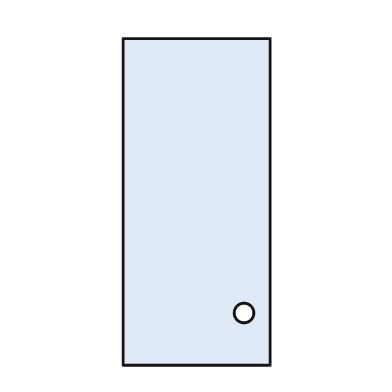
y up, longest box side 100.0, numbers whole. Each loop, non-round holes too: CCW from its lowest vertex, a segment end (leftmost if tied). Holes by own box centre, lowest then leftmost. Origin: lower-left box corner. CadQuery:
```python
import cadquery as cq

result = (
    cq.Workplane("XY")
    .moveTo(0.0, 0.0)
    .lineTo(45.0, 0.0)
    .lineTo(45.0, 100.0)
    .lineTo(0.0, 100.0)
    .close()
    .moveTo(37.0, 16.0)
    .circle(3.0)
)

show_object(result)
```